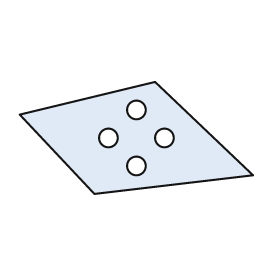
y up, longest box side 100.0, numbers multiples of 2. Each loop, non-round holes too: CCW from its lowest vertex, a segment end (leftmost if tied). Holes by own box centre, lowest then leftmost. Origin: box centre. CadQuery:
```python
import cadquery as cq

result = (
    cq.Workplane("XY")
    .moveTo(-18.0, -24.0)
    .lineTo(50.0, -16.0)
    .lineTo(8.0, 24.0)
    .lineTo(-50.0, 10.0)
    .close()
    .moveTo(0.0, -12.0)
    .circle(4.0)
    .moveTo(-12.0, 0.0)
    .circle(4.0)
    .moveTo(12.0, 0.0)
    .circle(4.0)
    .moveTo(0.0, 12.0)
    .circle(4.0)
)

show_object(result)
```